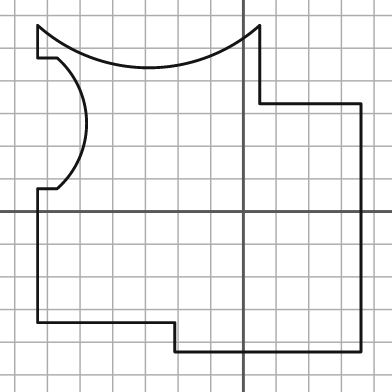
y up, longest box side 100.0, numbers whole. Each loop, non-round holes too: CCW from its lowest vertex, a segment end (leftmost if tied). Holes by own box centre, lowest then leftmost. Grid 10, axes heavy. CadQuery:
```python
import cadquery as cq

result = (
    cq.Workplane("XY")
    .moveTo(-21.0, -43.0)
    .lineTo(36.0, -43.0)
    .lineTo(36.0, 33.0)
    .lineTo(5.0, 33.0)
    .lineTo(5.0, 57.0)
    .threePointArc((-29.0, 44.0), (-63.0, 57.0))
    .lineTo(-63.0, 47.0)
    .lineTo(-57.0, 47.0)
    .threePointArc((-48.0, 27.0), (-57.0, 7.0))
    .lineTo(-63.0, 7.0)
    .lineTo(-63.0, -34.0)
    .lineTo(-21.0, -34.0)
    .close()
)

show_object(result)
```